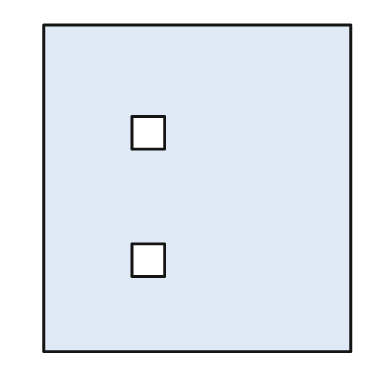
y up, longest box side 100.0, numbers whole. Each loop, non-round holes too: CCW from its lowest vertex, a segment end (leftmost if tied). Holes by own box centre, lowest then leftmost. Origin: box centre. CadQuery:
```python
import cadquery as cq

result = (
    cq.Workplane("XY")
    .moveTo(-47.0, -50.0)
    .lineTo(47.0, -50.0)
    .lineTo(47.0, 50.0)
    .lineTo(-47.0, 50.0)
    .close()
    .moveTo(-20.0, -27.0)
    .lineTo(-10.0, -27.0)
    .lineTo(-10.0, -17.0)
    .lineTo(-20.0, -17.0)
    .close()
    .moveTo(-20.0, 12.0)
    .lineTo(-10.0, 12.0)
    .lineTo(-10.0, 22.0)
    .lineTo(-20.0, 22.0)
    .close()
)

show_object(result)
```